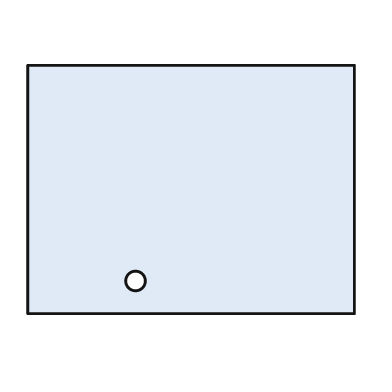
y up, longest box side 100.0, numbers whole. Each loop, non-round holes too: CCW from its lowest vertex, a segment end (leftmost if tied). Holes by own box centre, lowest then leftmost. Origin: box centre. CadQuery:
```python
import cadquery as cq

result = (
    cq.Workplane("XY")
    .moveTo(-50.0, -38.0)
    .lineTo(50.0, -38.0)
    .lineTo(50.0, 38.0)
    .lineTo(-50.0, 38.0)
    .close()
    .moveTo(-17.0, -28.0)
    .circle(3.0)
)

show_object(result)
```